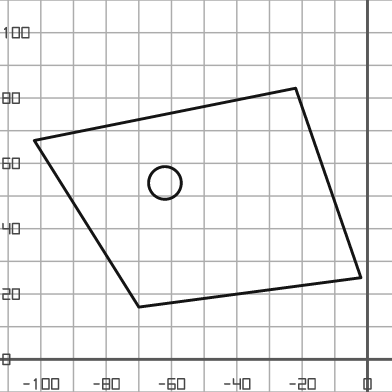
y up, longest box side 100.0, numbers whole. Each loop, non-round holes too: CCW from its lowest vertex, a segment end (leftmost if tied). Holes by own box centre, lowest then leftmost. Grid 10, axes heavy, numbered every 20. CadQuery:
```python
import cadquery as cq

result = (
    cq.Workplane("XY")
    .moveTo(-70.0, 16.0)
    .lineTo(-2.0, 25.0)
    .lineTo(-22.0, 83.0)
    .lineTo(-102.0, 67.0)
    .close()
    .moveTo(-62.0, 54.0)
    .circle(5.0)
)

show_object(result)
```